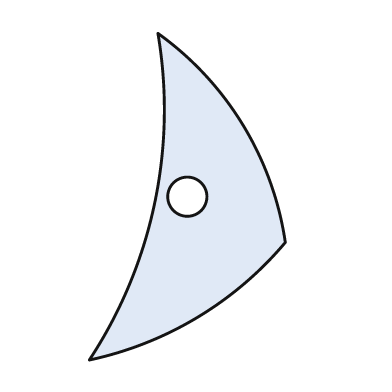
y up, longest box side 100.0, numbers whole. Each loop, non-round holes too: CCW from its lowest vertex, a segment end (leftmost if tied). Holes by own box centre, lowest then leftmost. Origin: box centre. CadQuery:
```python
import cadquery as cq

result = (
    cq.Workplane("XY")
    .moveTo(-30.0, -50.0)
    .threePointArc((3.0, -37.0), (30.0, -14.0))
    .threePointArc((17.0, 22.0), (-9.0, 50.0))
    .threePointArc((-10.0, -2.0), (-30.0, -50.0))
    .close()
    .moveTo(0.0, 0.0)
    .circle(6.0)
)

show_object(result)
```